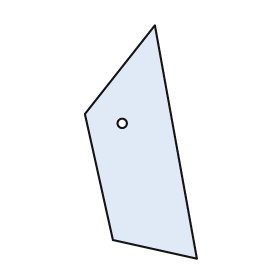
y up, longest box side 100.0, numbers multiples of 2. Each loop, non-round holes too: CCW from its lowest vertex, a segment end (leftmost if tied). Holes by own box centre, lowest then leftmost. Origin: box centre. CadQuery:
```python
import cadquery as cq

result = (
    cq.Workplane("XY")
    .moveTo(24.0, -50.0)
    .lineTo(6.0, 50.0)
    .lineTo(-24.0, 12.0)
    .lineTo(-12.0, -42.0)
    .close()
    .moveTo(-8.0, 8.0)
    .circle(2.0)
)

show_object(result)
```